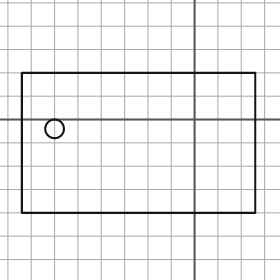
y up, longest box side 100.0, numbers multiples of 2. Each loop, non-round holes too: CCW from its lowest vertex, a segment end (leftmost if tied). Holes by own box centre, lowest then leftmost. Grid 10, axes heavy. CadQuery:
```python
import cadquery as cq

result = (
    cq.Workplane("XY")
    .moveTo(-74.0, -40.0)
    .lineTo(26.0, -40.0)
    .lineTo(26.0, 20.0)
    .lineTo(-74.0, 20.0)
    .close()
    .moveTo(-60.0, -4.0)
    .circle(4.0)
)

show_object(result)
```